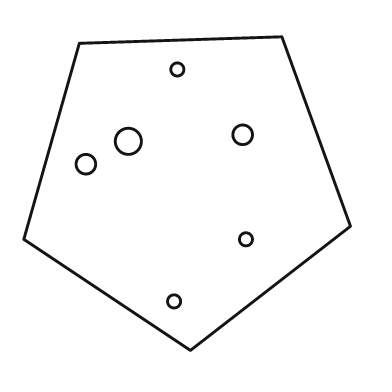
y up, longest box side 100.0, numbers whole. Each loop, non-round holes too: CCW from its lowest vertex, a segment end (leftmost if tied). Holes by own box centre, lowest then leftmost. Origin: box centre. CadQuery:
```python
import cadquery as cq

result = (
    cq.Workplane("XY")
    .moveTo(1.0, -48.0)
    .lineTo(50.0, -10.0)
    .lineTo(29.0, 48.0)
    .lineTo(-33.0, 46.0)
    .lineTo(-50.0, -14.0)
    .close()
    .moveTo(-4.0, -33.0)
    .circle(2.0)
    .moveTo(18.0, -14.0)
    .circle(2.0)
    .moveTo(-31.0, 9.0)
    .circle(3.0)
    .moveTo(-18.0, 16.0)
    .circle(4.0)
    .moveTo(17.0, 18.0)
    .circle(3.0)
    .moveTo(-3.0, 38.0)
    .circle(2.0)
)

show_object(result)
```